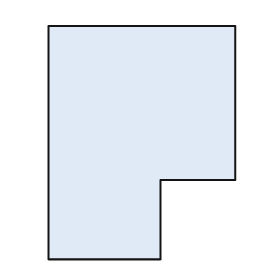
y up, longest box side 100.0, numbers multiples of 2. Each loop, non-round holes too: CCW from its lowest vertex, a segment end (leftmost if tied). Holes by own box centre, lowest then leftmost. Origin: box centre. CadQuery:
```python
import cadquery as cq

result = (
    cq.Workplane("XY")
    .moveTo(-40.0, -50.0)
    .lineTo(8.0, -50.0)
    .lineTo(8.0, -16.0)
    .lineTo(40.0, -16.0)
    .lineTo(40.0, 50.0)
    .lineTo(-40.0, 50.0)
    .close()
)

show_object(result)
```